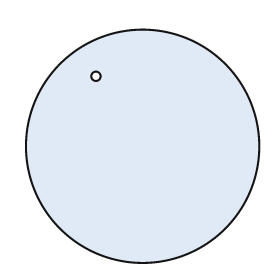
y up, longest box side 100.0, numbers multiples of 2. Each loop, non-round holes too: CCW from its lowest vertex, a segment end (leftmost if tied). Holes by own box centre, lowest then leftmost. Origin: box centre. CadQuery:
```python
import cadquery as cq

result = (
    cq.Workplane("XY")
    .moveTo(0.0, 0.0)
    .circle(50.0)
    .moveTo(-20.0, 30.0)
    .circle(2.0)
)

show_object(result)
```